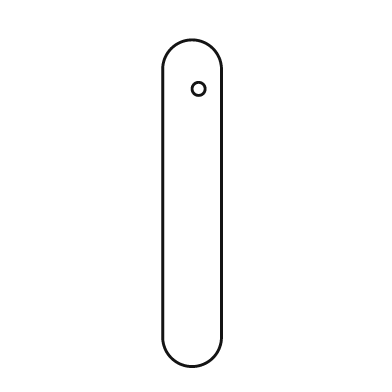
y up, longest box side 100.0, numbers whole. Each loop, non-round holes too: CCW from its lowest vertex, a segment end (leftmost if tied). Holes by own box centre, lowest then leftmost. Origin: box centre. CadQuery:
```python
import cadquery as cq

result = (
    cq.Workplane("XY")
    .moveTo(-9.0, -41.0)
    .threePointArc((0.0, -50.0), (9.0, -41.0))
    .lineTo(9.0, 41.0)
    .threePointArc((0.0, 50.0), (-9.0, 41.0))
    .close()
    .moveTo(2.0, 35.0)
    .circle(2.0)
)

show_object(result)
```